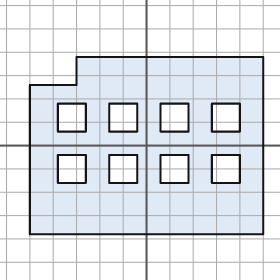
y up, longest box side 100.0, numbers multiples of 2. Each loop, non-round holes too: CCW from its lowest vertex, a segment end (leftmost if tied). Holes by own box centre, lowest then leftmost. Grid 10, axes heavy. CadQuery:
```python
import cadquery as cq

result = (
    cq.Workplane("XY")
    .moveTo(-50.0, -38.0)
    .lineTo(50.0, -38.0)
    .lineTo(50.0, 38.0)
    .lineTo(-30.0, 38.0)
    .lineTo(-30.0, 26.0)
    .lineTo(-50.0, 26.0)
    .close()
    .moveTo(-38.0, -16.0)
    .lineTo(-26.0, -16.0)
    .lineTo(-26.0, -4.0)
    .lineTo(-38.0, -4.0)
    .close()
    .moveTo(-16.0, -16.0)
    .lineTo(-4.0, -16.0)
    .lineTo(-4.0, -4.0)
    .lineTo(-16.0, -4.0)
    .close()
    .moveTo(6.0, -16.0)
    .lineTo(18.0, -16.0)
    .lineTo(18.0, -4.0)
    .lineTo(6.0, -4.0)
    .close()
    .moveTo(28.0, -16.0)
    .lineTo(40.0, -16.0)
    .lineTo(40.0, -4.0)
    .lineTo(28.0, -4.0)
    .close()
    .moveTo(-38.0, 6.0)
    .lineTo(-26.0, 6.0)
    .lineTo(-26.0, 18.0)
    .lineTo(-38.0, 18.0)
    .close()
    .moveTo(-16.0, 6.0)
    .lineTo(-4.0, 6.0)
    .lineTo(-4.0, 18.0)
    .lineTo(-16.0, 18.0)
    .close()
    .moveTo(6.0, 6.0)
    .lineTo(18.0, 6.0)
    .lineTo(18.0, 18.0)
    .lineTo(6.0, 18.0)
    .close()
    .moveTo(28.0, 6.0)
    .lineTo(40.0, 6.0)
    .lineTo(40.0, 18.0)
    .lineTo(28.0, 18.0)
    .close()
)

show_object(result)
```